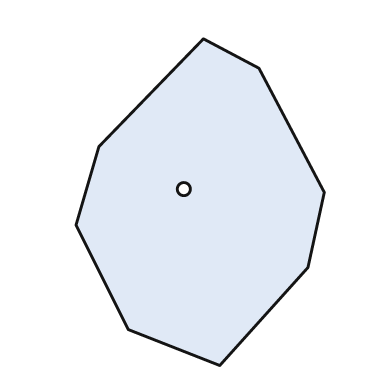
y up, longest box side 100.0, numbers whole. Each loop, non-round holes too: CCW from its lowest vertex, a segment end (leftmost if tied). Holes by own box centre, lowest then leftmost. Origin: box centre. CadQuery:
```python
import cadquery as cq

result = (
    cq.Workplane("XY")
    .moveTo(6.0, -50.0)
    .lineTo(33.0, -20.0)
    .lineTo(38.0, 3.0)
    .lineTo(18.0, 41.0)
    .lineTo(1.0, 50.0)
    .lineTo(-31.0, 17.0)
    .lineTo(-38.0, -7.0)
    .lineTo(-22.0, -39.0)
    .close()
    .moveTo(-5.0, 4.0)
    .circle(2.0)
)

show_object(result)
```